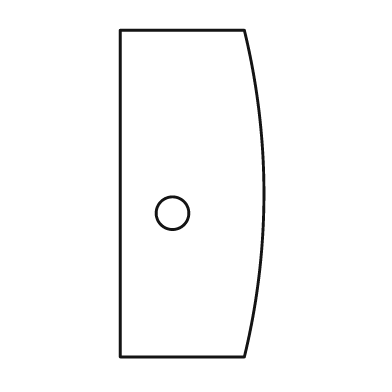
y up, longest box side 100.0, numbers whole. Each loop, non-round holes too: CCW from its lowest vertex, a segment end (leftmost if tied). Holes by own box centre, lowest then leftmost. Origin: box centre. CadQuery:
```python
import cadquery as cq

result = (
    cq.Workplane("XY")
    .moveTo(-22.0, -50.0)
    .lineTo(16.0, -50.0)
    .threePointArc((22.0, 0.0), (16.0, 50.0))
    .lineTo(-22.0, 50.0)
    .close()
    .moveTo(-6.0, -6.0)
    .circle(5.0)
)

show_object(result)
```